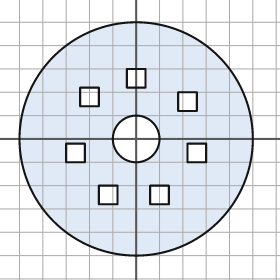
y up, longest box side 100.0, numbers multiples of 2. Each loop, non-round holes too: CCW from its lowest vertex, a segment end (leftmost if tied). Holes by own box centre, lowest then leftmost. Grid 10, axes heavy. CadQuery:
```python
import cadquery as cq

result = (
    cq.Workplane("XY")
    .moveTo(0.0, 0.0)
    .circle(50.0)
    .moveTo(-16.0, -28.0)
    .lineTo(-8.0, -28.0)
    .lineTo(-8.0, -20.0)
    .lineTo(-16.0, -20.0)
    .close()
    .moveTo(6.0, -28.0)
    .lineTo(14.0, -28.0)
    .lineTo(14.0, -20.0)
    .lineTo(6.0, -20.0)
    .close()
    .moveTo(-30.0, -10.0)
    .lineTo(-22.0, -10.0)
    .lineTo(-22.0, -2.0)
    .lineTo(-30.0, -2.0)
    .close()
    .moveTo(22.0, -10.0)
    .lineTo(30.0, -10.0)
    .lineTo(30.0, -2.0)
    .lineTo(22.0, -2.0)
    .close()
    .moveTo(0.0, 0.0)
    .circle(10.0)
    .moveTo(18.0, 12.0)
    .lineTo(26.0, 12.0)
    .lineTo(26.0, 20.0)
    .lineTo(18.0, 20.0)
    .close()
    .moveTo(-24.0, 14.0)
    .lineTo(-16.0, 14.0)
    .lineTo(-16.0, 22.0)
    .lineTo(-24.0, 22.0)
    .close()
    .moveTo(-4.0, 22.0)
    .lineTo(4.0, 22.0)
    .lineTo(4.0, 30.0)
    .lineTo(-4.0, 30.0)
    .close()
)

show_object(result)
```